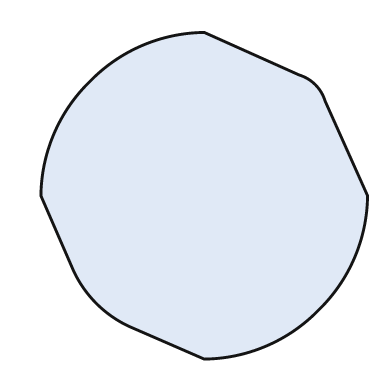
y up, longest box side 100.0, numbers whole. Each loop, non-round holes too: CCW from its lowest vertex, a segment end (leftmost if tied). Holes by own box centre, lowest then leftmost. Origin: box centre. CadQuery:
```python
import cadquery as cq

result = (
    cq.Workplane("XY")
    .moveTo(0.0, -50.0)
    .threePointArc((19.0, -46.0), (35.0, -35.0))
    .threePointArc((46.0, -19.0), (50.0, 0.0))
    .lineTo(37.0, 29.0)
    .threePointArc((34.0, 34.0), (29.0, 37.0))
    .lineTo(0.0, 50.0)
    .threePointArc((-19.0, 46.0), (-35.0, 35.0))
    .threePointArc((-46.0, 19.0), (-50.0, 0.0))
    .lineTo(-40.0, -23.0)
    .threePointArc((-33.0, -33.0), (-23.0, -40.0))
    .close()
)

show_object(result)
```